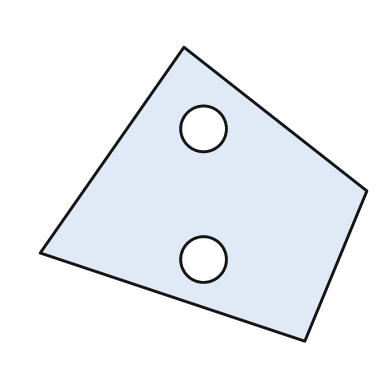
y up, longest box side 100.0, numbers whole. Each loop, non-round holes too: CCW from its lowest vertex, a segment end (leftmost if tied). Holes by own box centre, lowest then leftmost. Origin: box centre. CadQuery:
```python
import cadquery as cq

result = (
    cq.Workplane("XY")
    .moveTo(31.0, -45.0)
    .lineTo(50.0, 1.0)
    .lineTo(-6.0, 45.0)
    .lineTo(-50.0, -18.0)
    .close()
    .moveTo(0.0, -20.0)
    .circle(7.0)
    .moveTo(0.0, 20.0)
    .circle(7.0)
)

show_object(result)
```